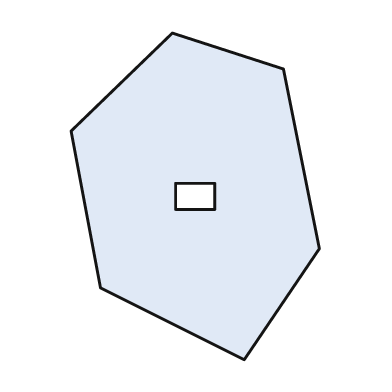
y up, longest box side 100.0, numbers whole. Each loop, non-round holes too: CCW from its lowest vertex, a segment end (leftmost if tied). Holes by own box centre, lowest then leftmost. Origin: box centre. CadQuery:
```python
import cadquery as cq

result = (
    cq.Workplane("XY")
    .moveTo(15.0, -50.0)
    .lineTo(38.0, -16.0)
    .lineTo(27.0, 39.0)
    .lineTo(-7.0, 50.0)
    .lineTo(-38.0, 20.0)
    .lineTo(-29.0, -28.0)
    .close()
    .moveTo(-6.0, -4.0)
    .lineTo(6.0, -4.0)
    .lineTo(6.0, 4.0)
    .lineTo(-6.0, 4.0)
    .close()
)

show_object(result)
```